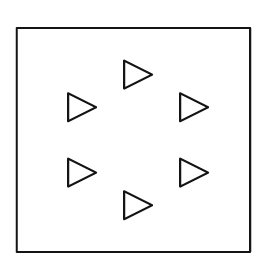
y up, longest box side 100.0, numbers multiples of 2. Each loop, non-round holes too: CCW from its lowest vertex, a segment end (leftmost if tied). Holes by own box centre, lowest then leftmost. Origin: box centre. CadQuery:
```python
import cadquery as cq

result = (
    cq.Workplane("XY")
    .moveTo(-50.0, -48.0)
    .lineTo(50.0, -48.0)
    .lineTo(50.0, 48.0)
    .lineTo(-50.0, 48.0)
    .close()
    .moveTo(-4.0, -34.0)
    .lineTo(8.0, -28.0)
    .lineTo(-4.0, -22.0)
    .close()
    .moveTo(-28.0, -20.0)
    .lineTo(-16.0, -14.0)
    .lineTo(-28.0, -8.0)
    .close()
    .moveTo(20.0, -20.0)
    .lineTo(32.0, -14.0)
    .lineTo(20.0, -8.0)
    .close()
    .moveTo(-28.0, 8.0)
    .lineTo(-16.0, 14.0)
    .lineTo(-28.0, 20.0)
    .close()
    .moveTo(20.0, 8.0)
    .lineTo(32.0, 14.0)
    .lineTo(20.0, 20.0)
    .close()
    .moveTo(-4.0, 22.0)
    .lineTo(8.0, 28.0)
    .lineTo(-4.0, 34.0)
    .close()
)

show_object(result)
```